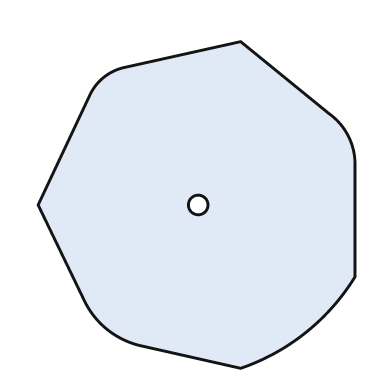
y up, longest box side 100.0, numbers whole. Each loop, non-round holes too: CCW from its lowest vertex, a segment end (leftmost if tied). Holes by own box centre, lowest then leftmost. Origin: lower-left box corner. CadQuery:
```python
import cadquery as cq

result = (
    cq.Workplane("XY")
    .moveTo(62.0, 0.0)
    .threePointArc((82.0, 11.0), (97.0, 28.0))
    .lineTo(97.0, 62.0)
    .threePointArc((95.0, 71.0), (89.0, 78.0))
    .lineTo(62.0, 100.0)
    .lineTo(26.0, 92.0)
    .threePointArc((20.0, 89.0), (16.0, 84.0))
    .lineTo(0.0, 50.0)
    .lineTo(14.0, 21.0)
    .threePointArc((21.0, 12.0), (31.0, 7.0))
    .close()
    .moveTo(49.0, 50.0)
    .circle(3.0)
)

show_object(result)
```